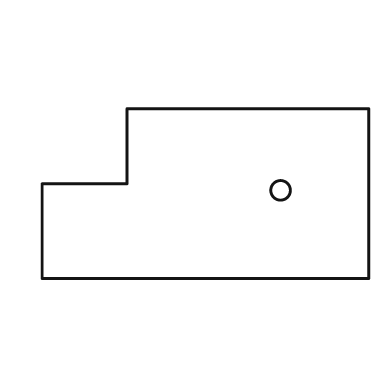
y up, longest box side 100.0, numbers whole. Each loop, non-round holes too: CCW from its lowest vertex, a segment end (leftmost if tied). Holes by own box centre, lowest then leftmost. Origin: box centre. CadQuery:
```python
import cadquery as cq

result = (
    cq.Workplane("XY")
    .moveTo(-50.0, -26.0)
    .lineTo(50.0, -26.0)
    .lineTo(50.0, 26.0)
    .lineTo(-24.0, 26.0)
    .lineTo(-24.0, 3.0)
    .lineTo(-50.0, 3.0)
    .close()
    .moveTo(23.0, 1.0)
    .circle(3.0)
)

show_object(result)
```